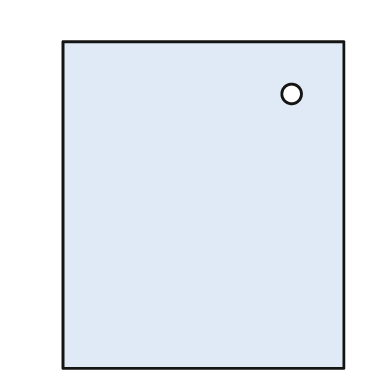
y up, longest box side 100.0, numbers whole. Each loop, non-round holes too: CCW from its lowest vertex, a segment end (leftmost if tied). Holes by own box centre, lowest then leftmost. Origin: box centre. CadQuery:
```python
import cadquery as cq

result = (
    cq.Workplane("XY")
    .moveTo(-43.0, -50.0)
    .lineTo(43.0, -50.0)
    .lineTo(43.0, 50.0)
    .lineTo(-43.0, 50.0)
    .close()
    .moveTo(27.0, 34.0)
    .circle(3.0)
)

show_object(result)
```